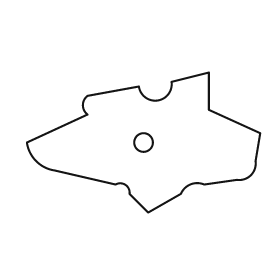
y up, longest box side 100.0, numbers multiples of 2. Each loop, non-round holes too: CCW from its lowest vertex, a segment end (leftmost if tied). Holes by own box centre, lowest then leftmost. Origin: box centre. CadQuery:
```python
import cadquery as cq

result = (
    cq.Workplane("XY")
    .moveTo(2.0, -30.0)
    .lineTo(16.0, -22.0)
    .threePointArc((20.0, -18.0), (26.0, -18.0))
    .lineTo(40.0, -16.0)
    .threePointArc((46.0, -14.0), (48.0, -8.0))
    .lineTo(50.0, 4.0)
    .lineTo(28.0, 14.0)
    .lineTo(28.0, 30.0)
    .lineTo(12.0, 26.0)
    .threePointArc((6.0, 18.0), (-2.0, 24.0))
    .lineTo(-24.0, 20.0)
    .threePointArc((-26.0, 16.0), (-24.0, 12.0))
    .lineTo(-50.0, 0.0)
    .threePointArc((-46.0, -8.0), (-38.0, -12.0))
    .lineTo(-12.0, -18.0)
    .threePointArc((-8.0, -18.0), (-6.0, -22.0))
    .close()
    .moveTo(0.0, 0.0)
    .circle(4.0)
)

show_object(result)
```